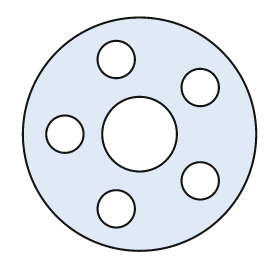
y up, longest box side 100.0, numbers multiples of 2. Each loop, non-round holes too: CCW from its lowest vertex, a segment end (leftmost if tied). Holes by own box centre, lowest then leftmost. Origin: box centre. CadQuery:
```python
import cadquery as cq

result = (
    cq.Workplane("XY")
    .moveTo(0.0, 0.0)
    .circle(50.0)
    .moveTo(-10.0, -32.0)
    .circle(8.0)
    .moveTo(26.0, -20.0)
    .circle(8.0)
    .moveTo(-32.0, 0.0)
    .circle(8.0)
    .moveTo(0.0, 0.0)
    .circle(16.0)
    .moveTo(26.0, 20.0)
    .circle(8.0)
    .moveTo(-10.0, 32.0)
    .circle(8.0)
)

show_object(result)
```